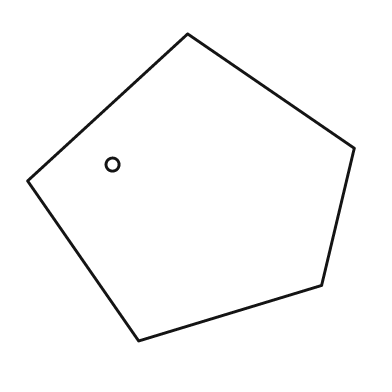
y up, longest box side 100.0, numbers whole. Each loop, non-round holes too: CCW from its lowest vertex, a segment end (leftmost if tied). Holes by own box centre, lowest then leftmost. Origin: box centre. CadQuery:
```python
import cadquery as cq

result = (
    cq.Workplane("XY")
    .moveTo(-16.0, -47.0)
    .lineTo(40.0, -30.0)
    .lineTo(50.0, 12.0)
    .lineTo(-1.0, 47.0)
    .lineTo(-50.0, 2.0)
    .close()
    .moveTo(-24.0, 7.0)
    .circle(2.0)
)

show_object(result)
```